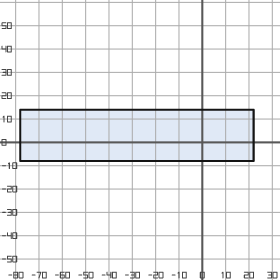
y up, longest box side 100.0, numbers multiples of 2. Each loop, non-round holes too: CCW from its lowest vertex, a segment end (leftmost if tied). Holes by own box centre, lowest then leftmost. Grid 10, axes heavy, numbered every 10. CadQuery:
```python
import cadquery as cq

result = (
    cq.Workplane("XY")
    .moveTo(-78.0, -8.0)
    .lineTo(22.0, -8.0)
    .lineTo(22.0, 14.0)
    .lineTo(-78.0, 14.0)
    .close()
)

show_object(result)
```